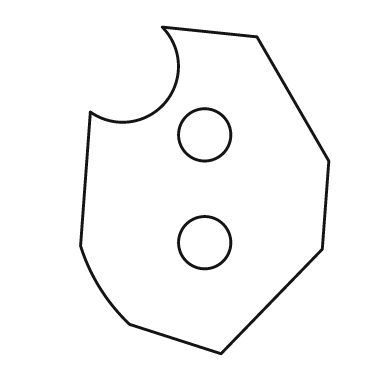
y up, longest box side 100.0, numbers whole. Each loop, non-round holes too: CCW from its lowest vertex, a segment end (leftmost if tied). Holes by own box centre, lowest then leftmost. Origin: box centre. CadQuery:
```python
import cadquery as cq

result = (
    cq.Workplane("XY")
    .moveTo(5.0, -50.0)
    .lineTo(36.0, -18.0)
    .lineTo(38.0, 9.0)
    .lineTo(16.0, 47.0)
    .lineTo(-13.0, 50.0)
    .threePointArc((-12.0, 27.0), (-35.0, 24.0))
    .lineTo(-38.0, -17.0)
    .threePointArc((-32.0, -30.0), (-23.0, -41.0))
    .close()
    .moveTo(0.0, -16.0)
    .circle(8.0)
    .moveTo(0.0, 17.0)
    .circle(8.0)
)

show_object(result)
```